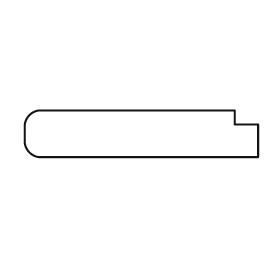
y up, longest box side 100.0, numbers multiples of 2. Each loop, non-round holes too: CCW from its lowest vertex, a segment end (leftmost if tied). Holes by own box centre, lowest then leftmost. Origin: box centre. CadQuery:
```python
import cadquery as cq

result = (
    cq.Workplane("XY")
    .moveTo(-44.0, -10.0)
    .lineTo(50.0, -10.0)
    .lineTo(50.0, 4.0)
    .lineTo(40.0, 4.0)
    .lineTo(40.0, 10.0)
    .lineTo(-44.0, 10.0)
    .threePointArc((-48.0, 8.0), (-50.0, 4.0))
    .lineTo(-50.0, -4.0)
    .threePointArc((-48.0, -8.0), (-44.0, -10.0))
    .close()
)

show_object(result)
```